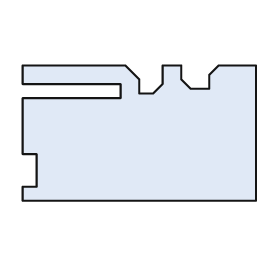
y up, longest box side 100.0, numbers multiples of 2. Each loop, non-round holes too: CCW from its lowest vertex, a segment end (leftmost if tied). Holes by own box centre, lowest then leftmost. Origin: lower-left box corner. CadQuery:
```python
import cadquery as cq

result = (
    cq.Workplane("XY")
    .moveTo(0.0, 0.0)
    .lineTo(100.0, 0.0)
    .lineTo(100.0, 58.0)
    .lineTo(84.0, 58.0)
    .lineTo(80.0, 54.0)
    .lineTo(80.0, 48.0)
    .lineTo(72.0, 48.0)
    .lineTo(68.0, 52.0)
    .lineTo(68.0, 58.0)
    .lineTo(60.0, 58.0)
    .lineTo(60.0, 50.0)
    .lineTo(56.0, 46.0)
    .lineTo(50.0, 46.0)
    .lineTo(50.0, 52.0)
    .lineTo(44.0, 58.0)
    .lineTo(0.0, 58.0)
    .lineTo(0.0, 50.0)
    .lineTo(42.0, 50.0)
    .lineTo(42.0, 44.0)
    .lineTo(0.0, 44.0)
    .lineTo(0.0, 20.0)
    .lineTo(6.0, 20.0)
    .lineTo(6.0, 6.0)
    .lineTo(0.0, 6.0)
    .close()
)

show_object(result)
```